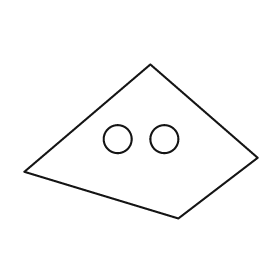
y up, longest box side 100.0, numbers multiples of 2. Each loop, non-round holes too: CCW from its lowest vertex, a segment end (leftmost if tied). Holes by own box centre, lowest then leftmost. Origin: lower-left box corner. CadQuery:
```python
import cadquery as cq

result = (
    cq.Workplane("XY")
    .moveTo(66.0, 0.0)
    .lineTo(100.0, 26.0)
    .lineTo(54.0, 66.0)
    .lineTo(0.0, 20.0)
    .close()
    .moveTo(40.0, 34.0)
    .circle(6.0)
    .moveTo(60.0, 34.0)
    .circle(6.0)
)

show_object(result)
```